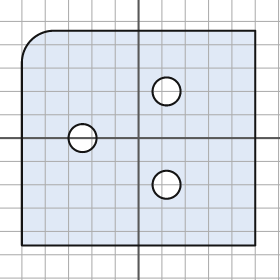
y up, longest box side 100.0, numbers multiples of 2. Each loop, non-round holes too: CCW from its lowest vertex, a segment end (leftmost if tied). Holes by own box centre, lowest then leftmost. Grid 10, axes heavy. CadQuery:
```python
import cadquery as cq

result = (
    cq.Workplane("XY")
    .moveTo(-50.0, -46.0)
    .lineTo(50.0, -46.0)
    .lineTo(50.0, 46.0)
    .lineTo(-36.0, 46.0)
    .threePointArc((-46.0, 42.0), (-50.0, 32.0))
    .close()
    .moveTo(12.0, -20.0)
    .circle(6.0)
    .moveTo(-24.0, 0.0)
    .circle(6.0)
    .moveTo(12.0, 20.0)
    .circle(6.0)
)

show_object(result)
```